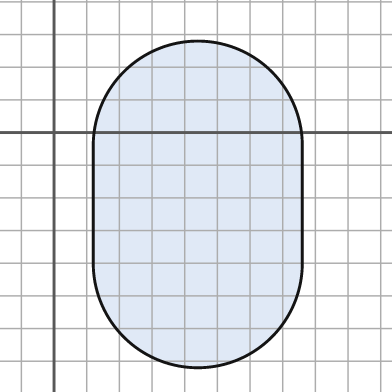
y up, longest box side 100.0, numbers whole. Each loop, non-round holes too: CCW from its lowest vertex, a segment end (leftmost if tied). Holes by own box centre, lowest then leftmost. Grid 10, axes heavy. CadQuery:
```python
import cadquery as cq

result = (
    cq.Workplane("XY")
    .moveTo(12.0, -40.0)
    .threePointArc((44.0, -72.0), (76.0, -40.0))
    .lineTo(76.0, -4.0)
    .threePointArc((44.0, 28.0), (12.0, -4.0))
    .close()
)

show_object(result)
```